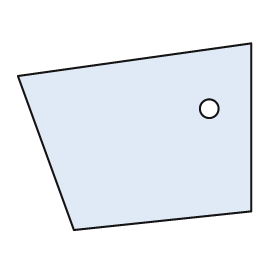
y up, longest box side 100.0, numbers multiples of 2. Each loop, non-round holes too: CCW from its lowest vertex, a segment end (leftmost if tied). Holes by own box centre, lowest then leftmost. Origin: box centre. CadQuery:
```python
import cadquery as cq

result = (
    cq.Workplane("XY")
    .moveTo(-26.0, -40.0)
    .lineTo(50.0, -32.0)
    .lineTo(50.0, 40.0)
    .lineTo(-50.0, 26.0)
    .close()
    .moveTo(32.0, 12.0)
    .circle(4.0)
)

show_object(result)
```